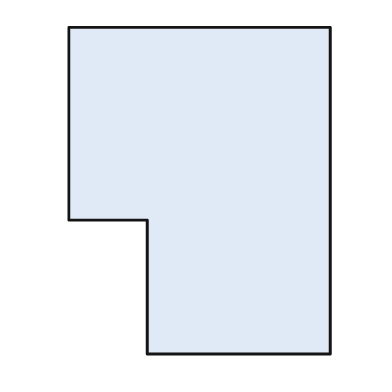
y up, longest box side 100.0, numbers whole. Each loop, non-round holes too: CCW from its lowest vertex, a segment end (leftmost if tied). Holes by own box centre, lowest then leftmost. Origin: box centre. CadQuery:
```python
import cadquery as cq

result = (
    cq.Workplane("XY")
    .moveTo(-16.0, -50.0)
    .lineTo(40.0, -50.0)
    .lineTo(40.0, 50.0)
    .lineTo(-40.0, 50.0)
    .lineTo(-40.0, -9.0)
    .lineTo(-16.0, -9.0)
    .close()
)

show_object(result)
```